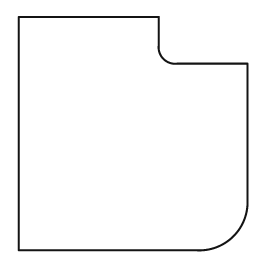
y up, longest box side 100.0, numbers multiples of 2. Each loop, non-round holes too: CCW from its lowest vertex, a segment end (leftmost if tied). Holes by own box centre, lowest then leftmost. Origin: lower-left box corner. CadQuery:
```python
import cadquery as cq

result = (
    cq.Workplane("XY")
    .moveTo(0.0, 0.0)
    .lineTo(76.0, 0.0)
    .threePointArc((92.0, 6.0), (98.0, 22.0))
    .lineTo(98.0, 80.0)
    .lineTo(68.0, 80.0)
    .threePointArc((62.0, 82.0), (60.0, 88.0))
    .lineTo(60.0, 100.0)
    .lineTo(0.0, 100.0)
    .close()
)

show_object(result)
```